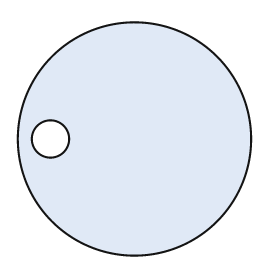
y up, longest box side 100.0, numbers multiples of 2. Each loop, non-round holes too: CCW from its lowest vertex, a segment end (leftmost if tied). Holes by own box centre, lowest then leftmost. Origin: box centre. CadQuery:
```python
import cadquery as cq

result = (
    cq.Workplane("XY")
    .moveTo(0.0, 0.0)
    .circle(50.0)
    .moveTo(-36.0, 0.0)
    .circle(8.0)
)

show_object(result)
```